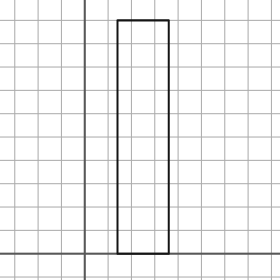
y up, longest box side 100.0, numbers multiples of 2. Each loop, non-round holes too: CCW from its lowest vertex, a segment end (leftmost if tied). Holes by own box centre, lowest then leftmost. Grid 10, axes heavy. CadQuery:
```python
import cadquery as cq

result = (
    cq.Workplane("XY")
    .moveTo(14.0, 0.0)
    .lineTo(36.0, 0.0)
    .lineTo(36.0, 100.0)
    .lineTo(14.0, 100.0)
    .close()
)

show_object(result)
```